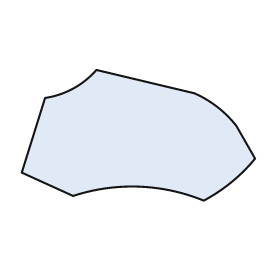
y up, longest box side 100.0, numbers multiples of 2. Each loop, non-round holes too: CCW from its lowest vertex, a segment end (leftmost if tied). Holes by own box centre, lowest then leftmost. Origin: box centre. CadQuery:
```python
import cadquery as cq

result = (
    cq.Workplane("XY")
    .moveTo(28.0, -28.0)
    .threePointArc((40.0, -20.0), (50.0, -10.0))
    .lineTo(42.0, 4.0)
    .threePointArc((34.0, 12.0), (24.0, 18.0))
    .lineTo(-18.0, 28.0)
    .threePointArc((-28.0, 20.0), (-40.0, 16.0))
    .lineTo(-50.0, -16.0)
    .lineTo(-28.0, -26.0)
    .threePointArc((0.0, -22.0), (28.0, -28.0))
    .close()
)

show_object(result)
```